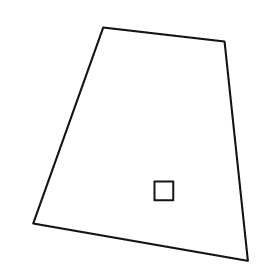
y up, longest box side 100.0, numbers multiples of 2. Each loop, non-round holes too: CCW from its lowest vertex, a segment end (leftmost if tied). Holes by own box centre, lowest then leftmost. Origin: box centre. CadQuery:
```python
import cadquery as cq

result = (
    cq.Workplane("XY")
    .moveTo(46.0, -50.0)
    .lineTo(36.0, 44.0)
    .lineTo(-16.0, 50.0)
    .lineTo(-46.0, -34.0)
    .close()
    .moveTo(6.0, -24.0)
    .lineTo(14.0, -24.0)
    .lineTo(14.0, -16.0)
    .lineTo(6.0, -16.0)
    .close()
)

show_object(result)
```